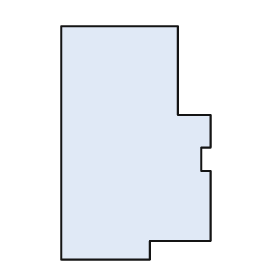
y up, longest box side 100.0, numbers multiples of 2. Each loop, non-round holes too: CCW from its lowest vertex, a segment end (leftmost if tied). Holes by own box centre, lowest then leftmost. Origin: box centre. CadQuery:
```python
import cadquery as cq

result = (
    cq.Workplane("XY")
    .moveTo(-32.0, -50.0)
    .lineTo(6.0, -50.0)
    .lineTo(6.0, -42.0)
    .lineTo(32.0, -42.0)
    .lineTo(32.0, -12.0)
    .lineTo(28.0, -12.0)
    .lineTo(28.0, -2.0)
    .lineTo(32.0, -2.0)
    .lineTo(32.0, 12.0)
    .lineTo(18.0, 12.0)
    .lineTo(18.0, 50.0)
    .lineTo(-32.0, 50.0)
    .close()
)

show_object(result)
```